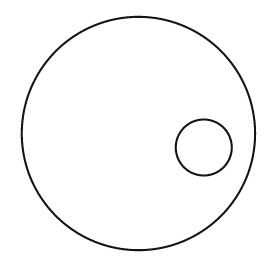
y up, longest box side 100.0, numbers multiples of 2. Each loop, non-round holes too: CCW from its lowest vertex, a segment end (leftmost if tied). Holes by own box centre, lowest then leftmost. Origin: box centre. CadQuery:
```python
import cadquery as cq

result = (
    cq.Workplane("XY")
    .moveTo(0.0, 0.0)
    .circle(50.0)
    .moveTo(28.0, -6.0)
    .circle(12.0)
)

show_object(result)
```